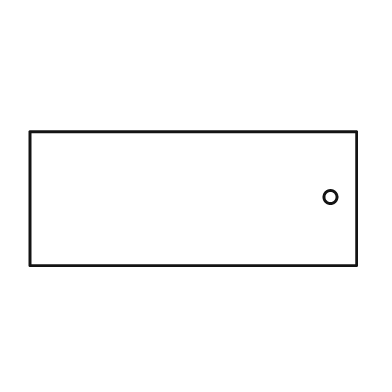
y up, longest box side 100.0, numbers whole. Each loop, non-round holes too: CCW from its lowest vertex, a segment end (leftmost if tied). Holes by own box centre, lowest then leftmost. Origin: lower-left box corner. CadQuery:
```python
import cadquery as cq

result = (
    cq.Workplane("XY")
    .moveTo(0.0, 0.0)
    .lineTo(100.0, 0.0)
    .lineTo(100.0, 41.0)
    .lineTo(0.0, 41.0)
    .close()
    .moveTo(92.0, 21.0)
    .circle(2.0)
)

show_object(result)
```